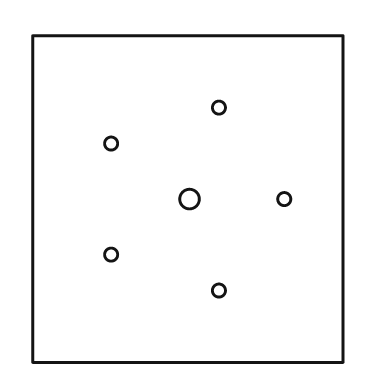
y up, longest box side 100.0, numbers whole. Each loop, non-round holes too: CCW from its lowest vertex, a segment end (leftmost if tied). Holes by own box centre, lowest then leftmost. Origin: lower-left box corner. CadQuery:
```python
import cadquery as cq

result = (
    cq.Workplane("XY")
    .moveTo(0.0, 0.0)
    .lineTo(95.0, 0.0)
    .lineTo(95.0, 100.0)
    .lineTo(0.0, 100.0)
    .close()
    .moveTo(57.0, 22.0)
    .circle(2.0)
    .moveTo(24.0, 33.0)
    .circle(2.0)
    .moveTo(48.0, 50.0)
    .circle(3.0)
    .moveTo(77.0, 50.0)
    .circle(2.0)
    .moveTo(24.0, 67.0)
    .circle(2.0)
    .moveTo(57.0, 78.0)
    .circle(2.0)
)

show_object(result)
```